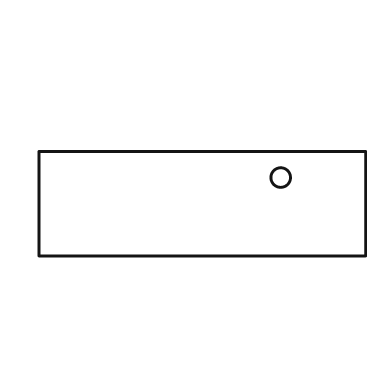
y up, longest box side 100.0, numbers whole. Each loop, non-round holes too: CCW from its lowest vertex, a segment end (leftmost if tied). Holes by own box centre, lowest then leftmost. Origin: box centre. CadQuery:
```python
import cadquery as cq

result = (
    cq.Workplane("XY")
    .moveTo(-50.0, -16.0)
    .lineTo(50.0, -16.0)
    .lineTo(50.0, 16.0)
    .lineTo(-50.0, 16.0)
    .close()
    .moveTo(24.0, 8.0)
    .circle(3.0)
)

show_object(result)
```